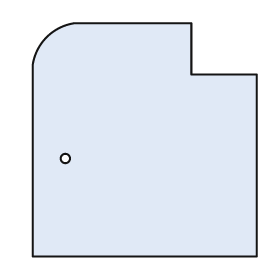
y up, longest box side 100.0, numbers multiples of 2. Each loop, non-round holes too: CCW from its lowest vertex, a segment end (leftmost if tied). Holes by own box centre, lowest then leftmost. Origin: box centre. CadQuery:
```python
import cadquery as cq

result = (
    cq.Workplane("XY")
    .moveTo(-48.0, -50.0)
    .lineTo(48.0, -50.0)
    .lineTo(48.0, 28.0)
    .lineTo(20.0, 28.0)
    .lineTo(20.0, 50.0)
    .lineTo(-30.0, 50.0)
    .threePointArc((-42.0, 44.0), (-48.0, 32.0))
    .close()
    .moveTo(-34.0, -8.0)
    .circle(2.0)
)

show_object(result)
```